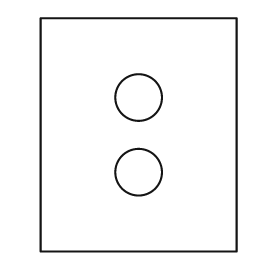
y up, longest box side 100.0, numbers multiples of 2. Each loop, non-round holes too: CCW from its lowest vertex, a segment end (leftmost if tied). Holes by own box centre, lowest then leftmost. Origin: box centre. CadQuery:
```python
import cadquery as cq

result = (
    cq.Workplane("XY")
    .moveTo(-42.0, -50.0)
    .lineTo(42.0, -50.0)
    .lineTo(42.0, 50.0)
    .lineTo(-42.0, 50.0)
    .close()
    .moveTo(0.0, -16.0)
    .circle(10.0)
    .moveTo(0.0, 16.0)
    .circle(10.0)
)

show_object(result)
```